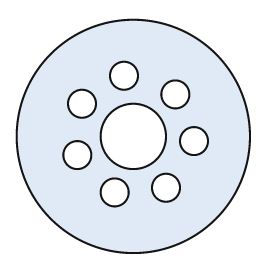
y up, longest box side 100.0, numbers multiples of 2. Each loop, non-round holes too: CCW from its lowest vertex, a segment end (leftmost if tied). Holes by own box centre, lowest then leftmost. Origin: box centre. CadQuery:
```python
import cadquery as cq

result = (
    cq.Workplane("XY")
    .moveTo(0.0, 0.0)
    .circle(50.0)
    .moveTo(-8.0, -24.0)
    .circle(6.0)
    .moveTo(14.0, -22.0)
    .circle(6.0)
    .moveTo(-24.0, -8.0)
    .circle(6.0)
    .moveTo(26.0, -2.0)
    .circle(6.0)
    .moveTo(0.0, 0.0)
    .circle(14.0)
    .moveTo(-22.0, 14.0)
    .circle(6.0)
    .moveTo(18.0, 18.0)
    .circle(6.0)
    .moveTo(-4.0, 26.0)
    .circle(6.0)
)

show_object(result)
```